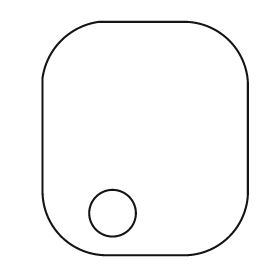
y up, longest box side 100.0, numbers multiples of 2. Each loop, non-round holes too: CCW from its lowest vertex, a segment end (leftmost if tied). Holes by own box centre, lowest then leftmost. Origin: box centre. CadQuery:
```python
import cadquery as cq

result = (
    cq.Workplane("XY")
    .moveTo(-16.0, -50.0)
    .lineTo(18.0, -50.0)
    .threePointArc((36.0, -42.0), (44.0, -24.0))
    .lineTo(44.0, 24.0)
    .threePointArc((36.0, 42.0), (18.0, 50.0))
    .lineTo(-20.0, 50.0)
    .threePointArc((-36.0, 42.0), (-44.0, 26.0))
    .lineTo(-44.0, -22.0)
    .threePointArc((-36.0, -42.0), (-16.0, -50.0))
    .close()
    .moveTo(-14.0, -32.0)
    .circle(10.0)
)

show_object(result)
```